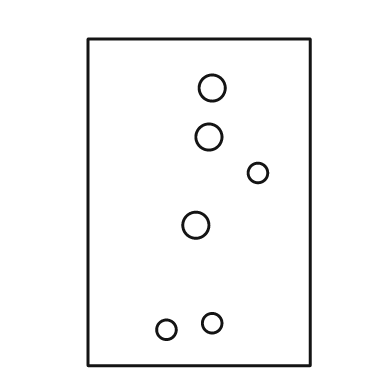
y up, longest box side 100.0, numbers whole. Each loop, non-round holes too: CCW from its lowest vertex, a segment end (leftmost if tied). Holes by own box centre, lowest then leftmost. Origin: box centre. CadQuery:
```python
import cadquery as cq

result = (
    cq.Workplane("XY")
    .moveTo(-34.0, -50.0)
    .lineTo(34.0, -50.0)
    .lineTo(34.0, 50.0)
    .lineTo(-34.0, 50.0)
    .close()
    .moveTo(-10.0, -39.0)
    .circle(3.0)
    .moveTo(4.0, -37.0)
    .circle(3.0)
    .moveTo(-1.0, -7.0)
    .circle(4.0)
    .moveTo(18.0, 9.0)
    .circle(3.0)
    .moveTo(3.0, 20.0)
    .circle(4.0)
    .moveTo(4.0, 35.0)
    .circle(4.0)
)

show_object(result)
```